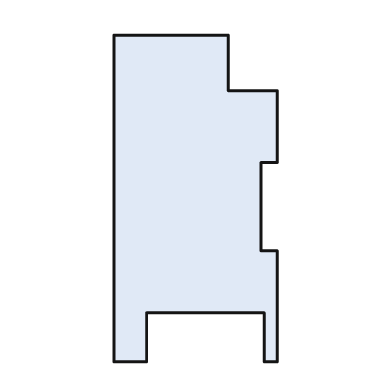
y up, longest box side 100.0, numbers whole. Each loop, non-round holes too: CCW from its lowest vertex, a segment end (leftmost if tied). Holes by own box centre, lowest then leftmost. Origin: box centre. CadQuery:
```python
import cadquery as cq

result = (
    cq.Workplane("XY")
    .moveTo(-25.0, -50.0)
    .lineTo(-15.0, -50.0)
    .lineTo(-15.0, -35.0)
    .lineTo(21.0, -35.0)
    .lineTo(21.0, -50.0)
    .lineTo(25.0, -50.0)
    .lineTo(25.0, -16.0)
    .lineTo(20.0, -16.0)
    .lineTo(20.0, 11.0)
    .lineTo(25.0, 11.0)
    .lineTo(25.0, 33.0)
    .lineTo(10.0, 33.0)
    .lineTo(10.0, 50.0)
    .lineTo(-25.0, 50.0)
    .close()
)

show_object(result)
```